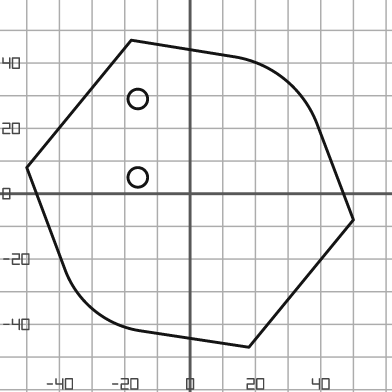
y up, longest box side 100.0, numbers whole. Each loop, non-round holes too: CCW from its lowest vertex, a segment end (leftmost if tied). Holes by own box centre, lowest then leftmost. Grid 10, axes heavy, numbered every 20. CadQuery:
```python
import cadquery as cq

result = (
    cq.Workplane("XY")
    .moveTo(18.0, -47.0)
    .lineTo(50.0, -8.0)
    .lineTo(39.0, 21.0)
    .threePointArc((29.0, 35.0), (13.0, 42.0))
    .lineTo(-18.0, 47.0)
    .lineTo(-50.0, 8.0)
    .lineTo(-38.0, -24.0)
    .threePointArc((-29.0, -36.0), (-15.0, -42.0))
    .close()
    .moveTo(-16.0, 5.0)
    .circle(3.0)
    .moveTo(-16.0, 29.0)
    .circle(3.0)
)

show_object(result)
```